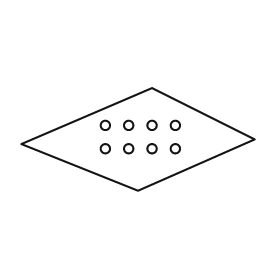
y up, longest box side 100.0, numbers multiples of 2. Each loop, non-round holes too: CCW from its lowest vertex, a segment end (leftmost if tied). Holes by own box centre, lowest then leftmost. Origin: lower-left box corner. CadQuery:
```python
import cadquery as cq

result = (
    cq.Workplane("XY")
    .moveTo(50.0, 0.0)
    .lineTo(100.0, 22.0)
    .lineTo(56.0, 44.0)
    .lineTo(0.0, 20.0)
    .close()
    .moveTo(36.0, 18.0)
    .circle(2.0)
    .moveTo(46.0, 18.0)
    .circle(2.0)
    .moveTo(56.0, 18.0)
    .circle(2.0)
    .moveTo(66.0, 18.0)
    .circle(2.0)
    .moveTo(36.0, 28.0)
    .circle(2.0)
    .moveTo(46.0, 28.0)
    .circle(2.0)
    .moveTo(56.0, 28.0)
    .circle(2.0)
    .moveTo(66.0, 28.0)
    .circle(2.0)
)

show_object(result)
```